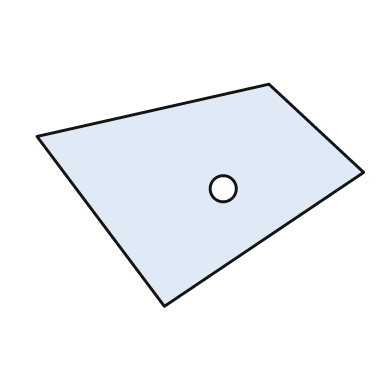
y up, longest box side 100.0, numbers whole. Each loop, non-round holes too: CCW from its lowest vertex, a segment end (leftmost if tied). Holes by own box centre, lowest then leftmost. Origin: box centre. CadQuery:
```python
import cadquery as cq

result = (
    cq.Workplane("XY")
    .moveTo(-11.0, -34.0)
    .lineTo(50.0, 7.0)
    .lineTo(21.0, 34.0)
    .lineTo(-50.0, 18.0)
    .close()
    .moveTo(7.0, 2.0)
    .circle(4.0)
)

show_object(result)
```